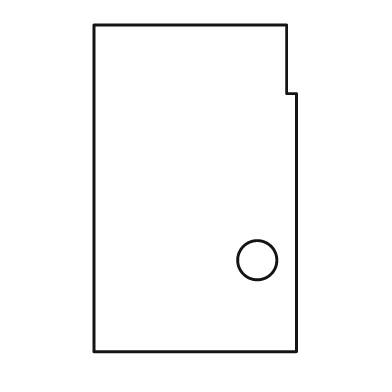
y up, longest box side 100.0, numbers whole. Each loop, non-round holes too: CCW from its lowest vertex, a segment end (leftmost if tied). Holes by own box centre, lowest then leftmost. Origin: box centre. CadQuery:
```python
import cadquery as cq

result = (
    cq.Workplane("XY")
    .moveTo(-31.0, -50.0)
    .lineTo(31.0, -50.0)
    .lineTo(31.0, 29.0)
    .lineTo(28.0, 29.0)
    .lineTo(28.0, 50.0)
    .lineTo(-31.0, 50.0)
    .close()
    .moveTo(19.0, -22.0)
    .circle(6.0)
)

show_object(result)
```